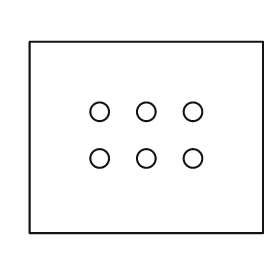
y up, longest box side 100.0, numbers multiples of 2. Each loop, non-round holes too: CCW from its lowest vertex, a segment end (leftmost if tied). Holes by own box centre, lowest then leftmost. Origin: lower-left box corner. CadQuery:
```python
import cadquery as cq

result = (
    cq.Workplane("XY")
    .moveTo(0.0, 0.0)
    .lineTo(100.0, 0.0)
    .lineTo(100.0, 82.0)
    .lineTo(0.0, 82.0)
    .close()
    .moveTo(30.0, 32.0)
    .circle(4.0)
    .moveTo(50.0, 32.0)
    .circle(4.0)
    .moveTo(70.0, 32.0)
    .circle(4.0)
    .moveTo(30.0, 52.0)
    .circle(4.0)
    .moveTo(50.0, 52.0)
    .circle(4.0)
    .moveTo(70.0, 52.0)
    .circle(4.0)
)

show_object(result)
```